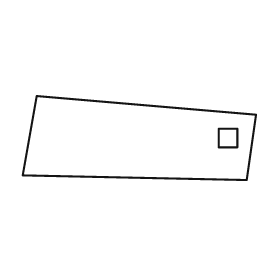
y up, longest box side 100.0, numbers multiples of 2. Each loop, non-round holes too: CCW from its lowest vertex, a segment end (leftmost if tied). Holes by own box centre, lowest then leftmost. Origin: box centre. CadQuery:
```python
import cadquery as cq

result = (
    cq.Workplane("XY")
    .moveTo(46.0, -18.0)
    .lineTo(50.0, 10.0)
    .lineTo(-44.0, 18.0)
    .lineTo(-50.0, -16.0)
    .close()
    .moveTo(34.0, -4.0)
    .lineTo(42.0, -4.0)
    .lineTo(42.0, 4.0)
    .lineTo(34.0, 4.0)
    .close()
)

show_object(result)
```